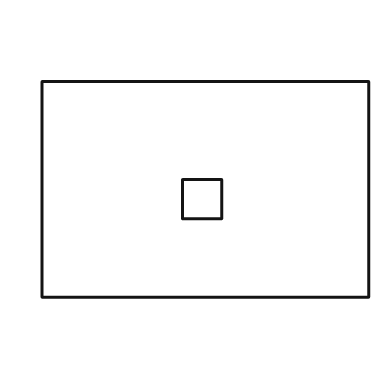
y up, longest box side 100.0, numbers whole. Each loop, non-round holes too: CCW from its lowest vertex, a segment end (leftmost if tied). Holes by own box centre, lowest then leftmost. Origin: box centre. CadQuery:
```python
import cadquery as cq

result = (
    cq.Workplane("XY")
    .moveTo(-50.0, -33.0)
    .lineTo(50.0, -33.0)
    .lineTo(50.0, 33.0)
    .lineTo(-50.0, 33.0)
    .close()
    .moveTo(-7.0, -9.0)
    .lineTo(5.0, -9.0)
    .lineTo(5.0, 3.0)
    .lineTo(-7.0, 3.0)
    .close()
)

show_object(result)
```